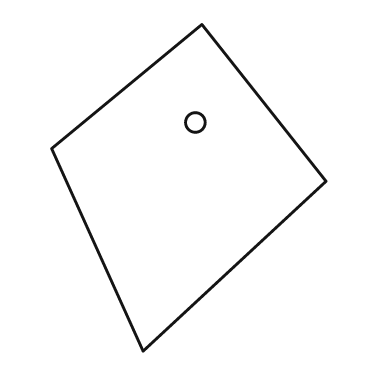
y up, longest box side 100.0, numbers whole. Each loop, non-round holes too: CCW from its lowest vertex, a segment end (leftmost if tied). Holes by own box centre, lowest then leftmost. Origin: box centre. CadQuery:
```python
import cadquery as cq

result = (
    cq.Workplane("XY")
    .moveTo(-14.0, -50.0)
    .lineTo(42.0, 2.0)
    .lineTo(4.0, 50.0)
    .lineTo(-42.0, 12.0)
    .close()
    .moveTo(2.0, 20.0)
    .circle(3.0)
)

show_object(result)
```